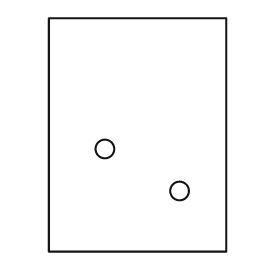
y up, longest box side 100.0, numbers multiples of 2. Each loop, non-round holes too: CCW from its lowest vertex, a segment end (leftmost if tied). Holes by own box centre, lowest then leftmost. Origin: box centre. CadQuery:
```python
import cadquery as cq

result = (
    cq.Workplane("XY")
    .moveTo(-38.0, -50.0)
    .lineTo(38.0, -50.0)
    .lineTo(38.0, 50.0)
    .lineTo(-38.0, 50.0)
    .close()
    .moveTo(18.0, -24.0)
    .circle(4.0)
    .moveTo(-14.0, -6.0)
    .circle(4.0)
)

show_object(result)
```